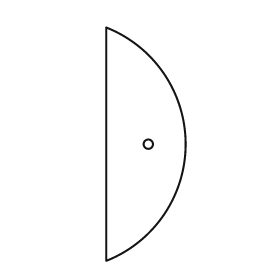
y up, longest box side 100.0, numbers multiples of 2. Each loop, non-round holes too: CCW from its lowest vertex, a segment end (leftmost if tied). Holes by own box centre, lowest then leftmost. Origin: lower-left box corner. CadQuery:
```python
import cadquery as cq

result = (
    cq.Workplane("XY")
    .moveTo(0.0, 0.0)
    .threePointArc((34.0, 50.0), (0.0, 100.0))
    .close()
    .moveTo(18.0, 50.0)
    .circle(2.0)
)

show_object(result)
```